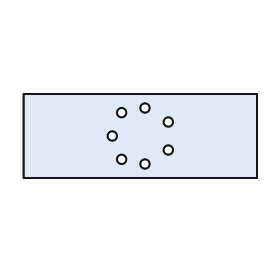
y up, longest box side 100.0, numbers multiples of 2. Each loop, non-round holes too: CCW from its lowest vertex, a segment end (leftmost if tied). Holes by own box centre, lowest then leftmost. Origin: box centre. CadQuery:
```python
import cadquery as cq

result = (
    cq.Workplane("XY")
    .moveTo(-50.0, -18.0)
    .lineTo(50.0, -18.0)
    .lineTo(50.0, 18.0)
    .lineTo(-50.0, 18.0)
    .close()
    .moveTo(2.0, -12.0)
    .circle(2.0)
    .moveTo(-8.0, -10.0)
    .circle(2.0)
    .moveTo(12.0, -6.0)
    .circle(2.0)
    .moveTo(-12.0, 0.0)
    .circle(2.0)
    .moveTo(12.0, 6.0)
    .circle(2.0)
    .moveTo(-8.0, 10.0)
    .circle(2.0)
    .moveTo(2.0, 12.0)
    .circle(2.0)
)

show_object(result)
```